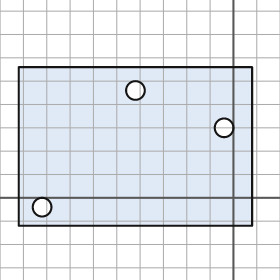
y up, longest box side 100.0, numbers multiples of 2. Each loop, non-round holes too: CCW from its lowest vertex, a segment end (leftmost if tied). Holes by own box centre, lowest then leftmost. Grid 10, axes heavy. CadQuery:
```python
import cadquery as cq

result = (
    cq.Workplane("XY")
    .moveTo(-92.0, -12.0)
    .lineTo(8.0, -12.0)
    .lineTo(8.0, 56.0)
    .lineTo(-92.0, 56.0)
    .close()
    .moveTo(-82.0, -4.0)
    .circle(4.0)
    .moveTo(-4.0, 30.0)
    .circle(4.0)
    .moveTo(-42.0, 46.0)
    .circle(4.0)
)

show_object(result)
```